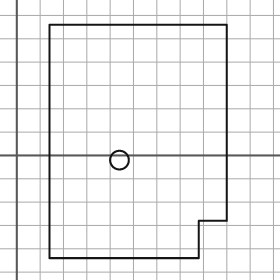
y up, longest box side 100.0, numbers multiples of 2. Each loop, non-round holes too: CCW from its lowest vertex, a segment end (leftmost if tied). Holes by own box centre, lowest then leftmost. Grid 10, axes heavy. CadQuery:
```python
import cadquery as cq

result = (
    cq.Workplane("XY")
    .moveTo(14.0, -44.0)
    .lineTo(78.0, -44.0)
    .lineTo(78.0, -28.0)
    .lineTo(90.0, -28.0)
    .lineTo(90.0, 56.0)
    .lineTo(14.0, 56.0)
    .close()
    .moveTo(44.0, -2.0)
    .circle(4.0)
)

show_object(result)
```